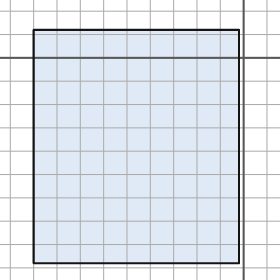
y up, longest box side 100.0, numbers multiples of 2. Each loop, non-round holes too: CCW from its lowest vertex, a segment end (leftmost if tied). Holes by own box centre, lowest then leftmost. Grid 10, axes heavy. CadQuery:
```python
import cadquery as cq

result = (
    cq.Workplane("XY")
    .moveTo(-90.0, -88.0)
    .lineTo(-2.0, -88.0)
    .lineTo(-2.0, 12.0)
    .lineTo(-90.0, 12.0)
    .close()
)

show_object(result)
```